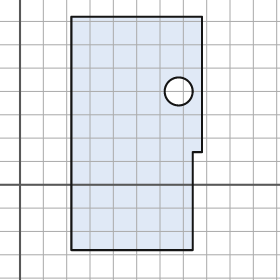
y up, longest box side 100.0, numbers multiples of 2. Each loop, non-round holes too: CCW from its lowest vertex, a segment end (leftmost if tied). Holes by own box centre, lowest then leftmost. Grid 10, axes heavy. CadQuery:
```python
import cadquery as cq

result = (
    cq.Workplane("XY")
    .moveTo(22.0, -28.0)
    .lineTo(74.0, -28.0)
    .lineTo(74.0, 14.0)
    .lineTo(78.0, 14.0)
    .lineTo(78.0, 72.0)
    .lineTo(22.0, 72.0)
    .close()
    .moveTo(68.0, 40.0)
    .circle(6.0)
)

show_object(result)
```